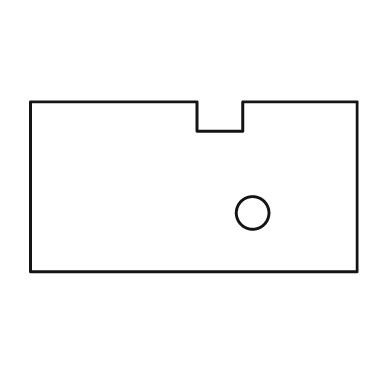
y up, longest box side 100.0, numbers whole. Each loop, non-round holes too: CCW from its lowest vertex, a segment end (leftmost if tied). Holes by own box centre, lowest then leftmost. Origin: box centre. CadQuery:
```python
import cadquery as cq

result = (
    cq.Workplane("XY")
    .moveTo(-50.0, -26.0)
    .lineTo(50.0, -26.0)
    .lineTo(50.0, 26.0)
    .lineTo(15.0, 26.0)
    .lineTo(15.0, 17.0)
    .lineTo(1.0, 17.0)
    .lineTo(1.0, 26.0)
    .lineTo(-50.0, 26.0)
    .close()
    .moveTo(18.0, -8.0)
    .circle(5.0)
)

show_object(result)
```